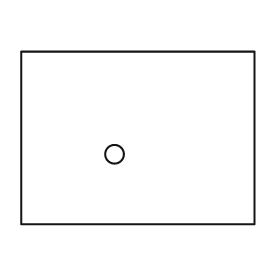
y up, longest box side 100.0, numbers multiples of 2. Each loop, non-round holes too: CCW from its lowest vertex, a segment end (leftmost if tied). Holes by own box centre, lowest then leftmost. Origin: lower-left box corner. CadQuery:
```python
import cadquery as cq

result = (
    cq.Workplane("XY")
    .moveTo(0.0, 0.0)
    .lineTo(100.0, 0.0)
    .lineTo(100.0, 74.0)
    .lineTo(0.0, 74.0)
    .close()
    .moveTo(40.0, 30.0)
    .circle(4.0)
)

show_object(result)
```